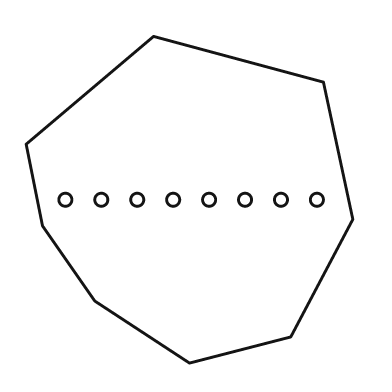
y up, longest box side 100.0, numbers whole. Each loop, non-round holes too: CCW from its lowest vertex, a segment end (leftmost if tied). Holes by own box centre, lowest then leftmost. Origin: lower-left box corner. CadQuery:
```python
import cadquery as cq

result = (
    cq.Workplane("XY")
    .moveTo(50.0, 0.0)
    .lineTo(81.0, 8.0)
    .lineTo(100.0, 44.0)
    .lineTo(91.0, 86.0)
    .lineTo(39.0, 100.0)
    .lineTo(0.0, 67.0)
    .lineTo(5.0, 42.0)
    .lineTo(21.0, 19.0)
    .close()
    .moveTo(12.0, 50.0)
    .circle(2.0)
    .moveTo(23.0, 50.0)
    .circle(2.0)
    .moveTo(34.0, 50.0)
    .circle(2.0)
    .moveTo(45.0, 50.0)
    .circle(2.0)
    .moveTo(56.0, 50.0)
    .circle(2.0)
    .moveTo(67.0, 50.0)
    .circle(2.0)
    .moveTo(78.0, 50.0)
    .circle(2.0)
    .moveTo(89.0, 50.0)
    .circle(2.0)
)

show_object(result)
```